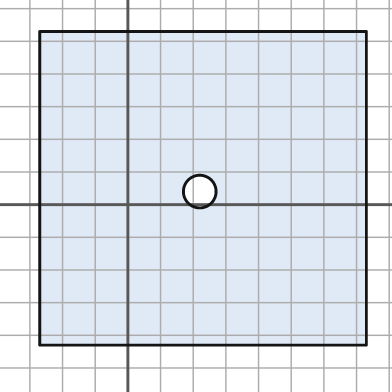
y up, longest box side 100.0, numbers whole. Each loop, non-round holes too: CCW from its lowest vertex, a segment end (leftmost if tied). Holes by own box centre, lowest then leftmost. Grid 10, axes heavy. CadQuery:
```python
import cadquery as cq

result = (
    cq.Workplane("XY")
    .moveTo(-27.0, -43.0)
    .lineTo(73.0, -43.0)
    .lineTo(73.0, 53.0)
    .lineTo(-27.0, 53.0)
    .close()
    .moveTo(22.0, 4.0)
    .circle(5.0)
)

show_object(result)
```